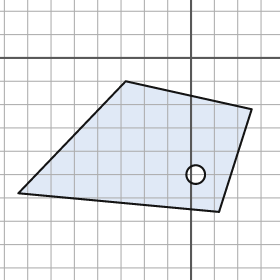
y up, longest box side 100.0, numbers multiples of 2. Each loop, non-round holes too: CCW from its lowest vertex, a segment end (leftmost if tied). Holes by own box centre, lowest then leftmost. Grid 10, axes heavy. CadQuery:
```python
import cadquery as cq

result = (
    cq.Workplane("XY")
    .moveTo(12.0, -66.0)
    .lineTo(26.0, -22.0)
    .lineTo(-28.0, -10.0)
    .lineTo(-74.0, -58.0)
    .close()
    .moveTo(2.0, -50.0)
    .circle(4.0)
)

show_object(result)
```